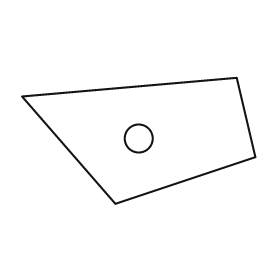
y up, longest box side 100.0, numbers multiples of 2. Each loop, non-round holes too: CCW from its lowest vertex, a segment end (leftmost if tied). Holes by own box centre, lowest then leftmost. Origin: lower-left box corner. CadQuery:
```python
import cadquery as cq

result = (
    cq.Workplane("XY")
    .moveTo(40.0, 0.0)
    .lineTo(100.0, 20.0)
    .lineTo(92.0, 54.0)
    .lineTo(0.0, 46.0)
    .close()
    .moveTo(50.0, 28.0)
    .circle(6.0)
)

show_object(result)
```